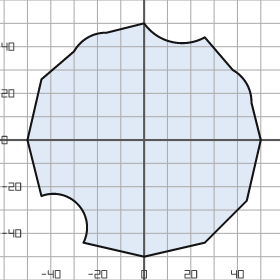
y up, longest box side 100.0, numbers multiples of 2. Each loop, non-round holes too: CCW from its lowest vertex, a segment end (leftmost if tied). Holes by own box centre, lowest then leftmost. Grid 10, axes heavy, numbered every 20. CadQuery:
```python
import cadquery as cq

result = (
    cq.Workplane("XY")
    .moveTo(0.0, -50.0)
    .lineTo(26.0, -44.0)
    .lineTo(44.0, -26.0)
    .lineTo(50.0, 0.0)
    .lineTo(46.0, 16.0)
    .threePointArc((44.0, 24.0), (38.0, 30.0))
    .lineTo(26.0, 44.0)
    .threePointArc((12.0, 42.0), (0.0, 50.0))
    .lineTo(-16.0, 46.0)
    .threePointArc((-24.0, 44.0), (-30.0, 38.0))
    .lineTo(-44.0, 26.0)
    .lineTo(-50.0, 0.0)
    .lineTo(-44.0, -24.0)
    .threePointArc((-28.0, -28.0), (-26.0, -44.0))
    .close()
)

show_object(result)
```